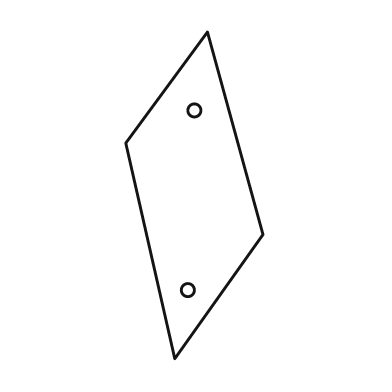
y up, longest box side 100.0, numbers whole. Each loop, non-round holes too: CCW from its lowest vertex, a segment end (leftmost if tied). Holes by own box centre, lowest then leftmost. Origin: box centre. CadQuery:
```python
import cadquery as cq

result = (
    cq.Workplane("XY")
    .moveTo(-6.0, -50.0)
    .lineTo(21.0, -12.0)
    .lineTo(4.0, 50.0)
    .lineTo(-21.0, 16.0)
    .close()
    .moveTo(-2.0, -29.0)
    .circle(2.0)
    .moveTo(0.0, 26.0)
    .circle(2.0)
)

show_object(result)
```